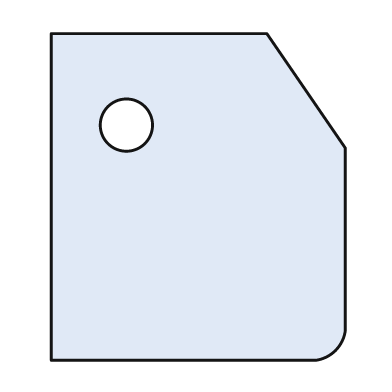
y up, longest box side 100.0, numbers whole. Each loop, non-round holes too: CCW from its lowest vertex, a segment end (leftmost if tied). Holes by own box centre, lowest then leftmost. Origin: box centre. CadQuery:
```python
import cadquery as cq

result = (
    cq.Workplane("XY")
    .moveTo(-45.0, -50.0)
    .lineTo(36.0, -50.0)
    .threePointArc((42.0, -47.0), (45.0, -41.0))
    .lineTo(45.0, 15.0)
    .lineTo(21.0, 50.0)
    .lineTo(-45.0, 50.0)
    .close()
    .moveTo(-22.0, 22.0)
    .circle(8.0)
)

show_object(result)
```